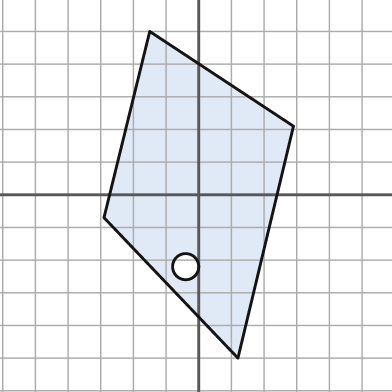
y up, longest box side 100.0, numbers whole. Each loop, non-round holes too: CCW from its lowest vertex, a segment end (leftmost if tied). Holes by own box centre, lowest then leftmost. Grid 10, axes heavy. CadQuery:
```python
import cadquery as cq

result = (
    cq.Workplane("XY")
    .moveTo(12.0, -50.0)
    .lineTo(29.0, 21.0)
    .lineTo(-15.0, 50.0)
    .lineTo(-29.0, -7.0)
    .close()
    .moveTo(-4.0, -22.0)
    .circle(4.0)
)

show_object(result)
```